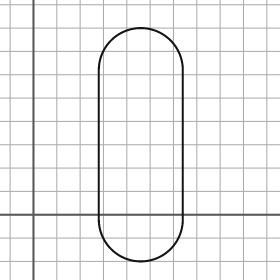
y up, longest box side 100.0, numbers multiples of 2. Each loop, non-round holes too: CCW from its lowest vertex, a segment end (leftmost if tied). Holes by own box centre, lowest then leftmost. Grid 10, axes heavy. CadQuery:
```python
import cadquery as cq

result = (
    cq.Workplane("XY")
    .moveTo(28.0, -2.0)
    .threePointArc((46.0, -20.0), (64.0, -2.0))
    .lineTo(64.0, 62.0)
    .threePointArc((46.0, 80.0), (28.0, 62.0))
    .close()
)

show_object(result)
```